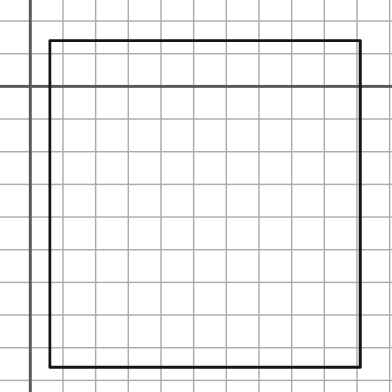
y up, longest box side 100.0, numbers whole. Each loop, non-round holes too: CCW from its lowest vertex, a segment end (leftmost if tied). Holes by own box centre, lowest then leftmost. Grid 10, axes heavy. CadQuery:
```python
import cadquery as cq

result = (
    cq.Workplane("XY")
    .moveTo(6.0, -86.0)
    .lineTo(101.0, -86.0)
    .lineTo(101.0, 14.0)
    .lineTo(6.0, 14.0)
    .close()
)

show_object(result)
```